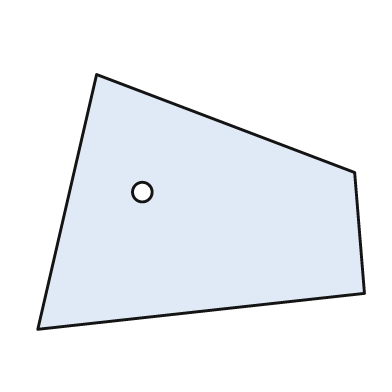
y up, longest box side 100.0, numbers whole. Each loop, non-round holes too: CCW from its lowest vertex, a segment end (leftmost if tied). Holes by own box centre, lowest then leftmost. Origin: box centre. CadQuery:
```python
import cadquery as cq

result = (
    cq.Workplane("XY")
    .moveTo(-50.0, -39.0)
    .lineTo(50.0, -28.0)
    .lineTo(47.0, 9.0)
    .lineTo(-32.0, 39.0)
    .close()
    .moveTo(-18.0, 3.0)
    .circle(3.0)
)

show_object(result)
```